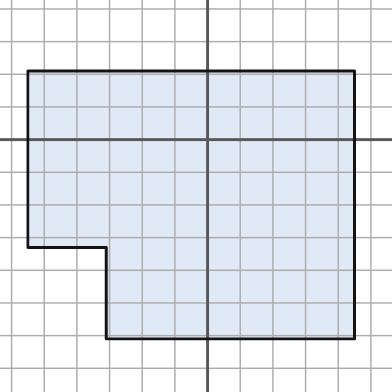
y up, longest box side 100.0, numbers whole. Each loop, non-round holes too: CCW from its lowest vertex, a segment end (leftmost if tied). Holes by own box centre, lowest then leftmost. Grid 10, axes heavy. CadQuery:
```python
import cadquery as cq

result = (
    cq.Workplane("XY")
    .moveTo(-31.0, -61.0)
    .lineTo(45.0, -61.0)
    .lineTo(45.0, 21.0)
    .lineTo(-55.0, 21.0)
    .lineTo(-55.0, -33.0)
    .lineTo(-31.0, -33.0)
    .close()
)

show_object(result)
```